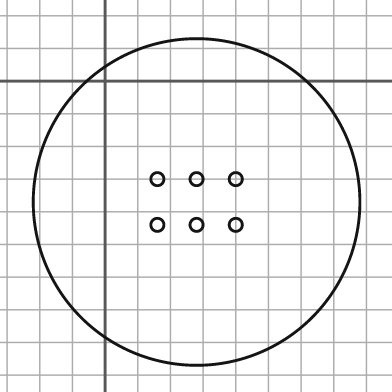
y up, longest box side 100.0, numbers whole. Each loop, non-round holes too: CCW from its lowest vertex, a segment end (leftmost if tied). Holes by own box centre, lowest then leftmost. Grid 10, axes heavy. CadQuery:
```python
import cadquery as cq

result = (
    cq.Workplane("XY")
    .moveTo(28.0, -37.0)
    .circle(50.0)
    .moveTo(16.0, -44.0)
    .circle(2.0)
    .moveTo(28.0, -44.0)
    .circle(2.0)
    .moveTo(40.0, -44.0)
    .circle(2.0)
    .moveTo(16.0, -30.0)
    .circle(2.0)
    .moveTo(28.0, -30.0)
    .circle(2.0)
    .moveTo(40.0, -30.0)
    .circle(2.0)
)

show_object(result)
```